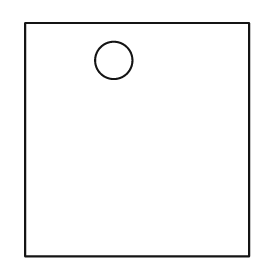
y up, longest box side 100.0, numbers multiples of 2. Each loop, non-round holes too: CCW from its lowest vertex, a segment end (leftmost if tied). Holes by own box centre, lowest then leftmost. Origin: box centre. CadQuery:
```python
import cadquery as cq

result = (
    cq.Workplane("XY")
    .moveTo(-48.0, -50.0)
    .lineTo(48.0, -50.0)
    .lineTo(48.0, 50.0)
    .lineTo(-48.0, 50.0)
    .close()
    .moveTo(-10.0, 34.0)
    .circle(8.0)
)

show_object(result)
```